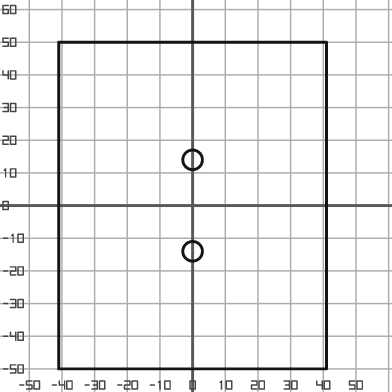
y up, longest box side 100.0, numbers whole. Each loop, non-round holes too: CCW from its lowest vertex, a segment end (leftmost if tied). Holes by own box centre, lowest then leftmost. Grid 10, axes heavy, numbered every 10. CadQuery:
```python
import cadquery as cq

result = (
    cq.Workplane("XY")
    .moveTo(-41.0, -50.0)
    .lineTo(41.0, -50.0)
    .lineTo(41.0, 50.0)
    .lineTo(-41.0, 50.0)
    .close()
    .moveTo(0.0, -14.0)
    .circle(3.0)
    .moveTo(0.0, 14.0)
    .circle(3.0)
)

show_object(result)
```